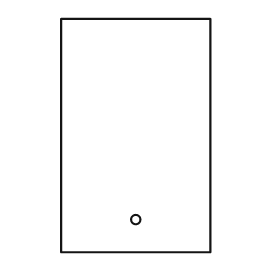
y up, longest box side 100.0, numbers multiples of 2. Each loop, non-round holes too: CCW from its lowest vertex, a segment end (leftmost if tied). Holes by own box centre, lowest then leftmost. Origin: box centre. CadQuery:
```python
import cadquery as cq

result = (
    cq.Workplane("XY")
    .moveTo(-32.0, -50.0)
    .lineTo(32.0, -50.0)
    .lineTo(32.0, 50.0)
    .lineTo(-32.0, 50.0)
    .close()
    .moveTo(0.0, -36.0)
    .circle(2.0)
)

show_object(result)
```